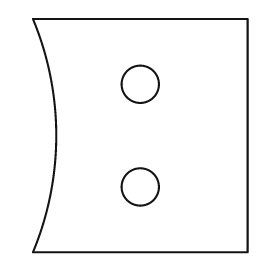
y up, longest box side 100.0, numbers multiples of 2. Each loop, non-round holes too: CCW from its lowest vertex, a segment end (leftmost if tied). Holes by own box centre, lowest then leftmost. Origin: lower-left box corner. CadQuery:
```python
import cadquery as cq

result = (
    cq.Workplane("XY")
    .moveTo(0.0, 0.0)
    .lineTo(92.0, 0.0)
    .lineTo(92.0, 100.0)
    .lineTo(0.0, 100.0)
    .threePointArc((10.0, 50.0), (0.0, 0.0))
    .close()
    .moveTo(46.0, 28.0)
    .circle(8.0)
    .moveTo(46.0, 72.0)
    .circle(8.0)
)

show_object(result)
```